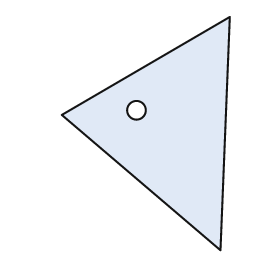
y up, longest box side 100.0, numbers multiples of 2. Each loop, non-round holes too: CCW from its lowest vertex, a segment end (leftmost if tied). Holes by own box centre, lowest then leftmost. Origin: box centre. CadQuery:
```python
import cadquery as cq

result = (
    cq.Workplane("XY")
    .moveTo(32.0, -50.0)
    .lineTo(36.0, 50.0)
    .lineTo(-36.0, 8.0)
    .close()
    .moveTo(-4.0, 10.0)
    .circle(4.0)
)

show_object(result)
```